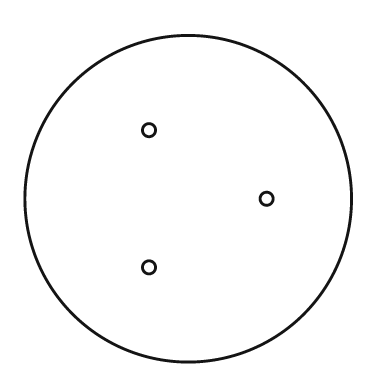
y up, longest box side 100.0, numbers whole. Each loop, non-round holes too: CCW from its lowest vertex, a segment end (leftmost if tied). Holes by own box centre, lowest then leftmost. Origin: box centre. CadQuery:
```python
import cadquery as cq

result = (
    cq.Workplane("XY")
    .moveTo(0.0, 0.0)
    .circle(50.0)
    .moveTo(-12.0, -21.0)
    .circle(2.0)
    .moveTo(24.0, 0.0)
    .circle(2.0)
    .moveTo(-12.0, 21.0)
    .circle(2.0)
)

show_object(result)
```